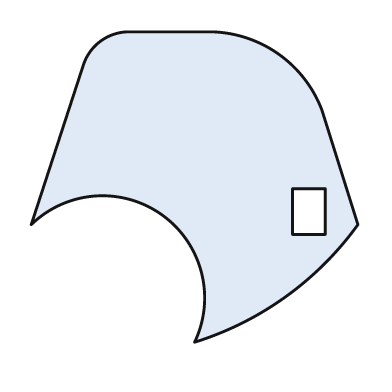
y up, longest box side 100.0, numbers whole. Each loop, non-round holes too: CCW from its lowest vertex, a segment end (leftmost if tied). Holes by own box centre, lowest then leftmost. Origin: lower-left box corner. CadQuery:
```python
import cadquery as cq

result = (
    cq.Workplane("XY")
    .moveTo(50.0, 0.0)
    .threePointArc((78.0, 14.0), (100.0, 36.0))
    .lineTo(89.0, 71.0)
    .threePointArc((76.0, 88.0), (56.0, 95.0))
    .lineTo(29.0, 95.0)
    .threePointArc((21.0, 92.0), (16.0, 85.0))
    .lineTo(0.0, 36.0)
    .threePointArc((40.0, 39.0), (50.0, 0.0))
    .close()
    .moveTo(80.0, 33.0)
    .lineTo(90.0, 33.0)
    .lineTo(90.0, 47.0)
    .lineTo(80.0, 47.0)
    .close()
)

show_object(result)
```